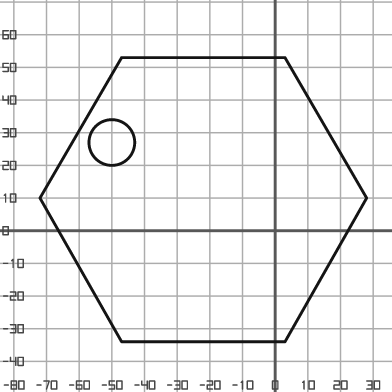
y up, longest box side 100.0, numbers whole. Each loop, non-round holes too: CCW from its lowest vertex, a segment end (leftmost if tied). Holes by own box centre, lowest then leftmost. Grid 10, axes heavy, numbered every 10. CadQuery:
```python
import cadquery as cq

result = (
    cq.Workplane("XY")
    .moveTo(-47.0, -34.0)
    .lineTo(3.0, -34.0)
    .lineTo(28.0, 10.0)
    .lineTo(3.0, 53.0)
    .lineTo(-47.0, 53.0)
    .lineTo(-72.0, 10.0)
    .close()
    .moveTo(-50.0, 27.0)
    .circle(7.0)
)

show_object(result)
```